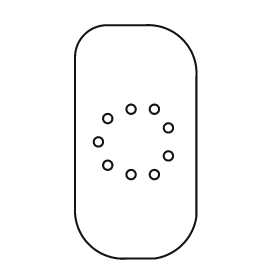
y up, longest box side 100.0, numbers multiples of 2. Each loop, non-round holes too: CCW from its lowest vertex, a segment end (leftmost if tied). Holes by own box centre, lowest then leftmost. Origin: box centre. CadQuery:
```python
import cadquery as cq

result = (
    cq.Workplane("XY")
    .moveTo(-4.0, -50.0)
    .lineTo(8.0, -50.0)
    .threePointArc((20.0, -44.0), (26.0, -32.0))
    .lineTo(26.0, 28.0)
    .threePointArc((20.0, 44.0), (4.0, 50.0))
    .lineTo(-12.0, 50.0)
    .threePointArc((-22.0, 46.0), (-26.0, 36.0))
    .lineTo(-26.0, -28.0)
    .threePointArc((-20.0, -44.0), (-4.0, -50.0))
    .close()
    .moveTo(-2.0, -14.0)
    .circle(2.0)
    .moveTo(8.0, -14.0)
    .circle(2.0)
    .moveTo(-12.0, -10.0)
    .circle(2.0)
    .moveTo(14.0, -6.0)
    .circle(2.0)
    .moveTo(-16.0, 0.0)
    .circle(2.0)
    .moveTo(14.0, 6.0)
    .circle(2.0)
    .moveTo(-12.0, 10.0)
    .circle(2.0)
    .moveTo(-2.0, 14.0)
    .circle(2.0)
    .moveTo(8.0, 14.0)
    .circle(2.0)
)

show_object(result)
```